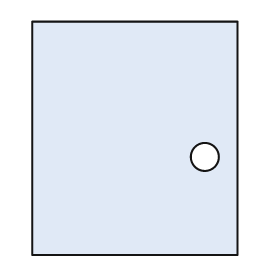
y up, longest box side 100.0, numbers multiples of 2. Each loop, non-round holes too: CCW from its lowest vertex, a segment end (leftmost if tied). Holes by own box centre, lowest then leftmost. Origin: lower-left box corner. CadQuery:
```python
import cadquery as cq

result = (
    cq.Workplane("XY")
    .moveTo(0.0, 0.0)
    .lineTo(88.0, 0.0)
    .lineTo(88.0, 100.0)
    .lineTo(0.0, 100.0)
    .close()
    .moveTo(74.0, 42.0)
    .circle(6.0)
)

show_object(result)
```